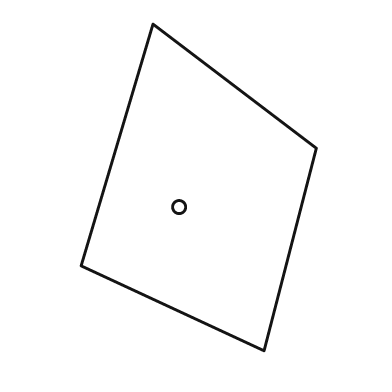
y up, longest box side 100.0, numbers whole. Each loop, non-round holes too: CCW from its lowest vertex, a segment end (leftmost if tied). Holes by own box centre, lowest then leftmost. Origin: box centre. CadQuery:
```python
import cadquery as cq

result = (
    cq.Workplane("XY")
    .moveTo(20.0, -50.0)
    .lineTo(36.0, 12.0)
    .lineTo(-14.0, 50.0)
    .lineTo(-36.0, -24.0)
    .close()
    .moveTo(-6.0, -6.0)
    .circle(2.0)
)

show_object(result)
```